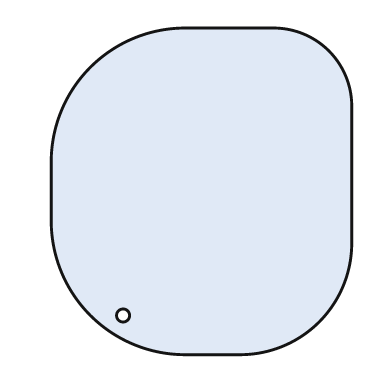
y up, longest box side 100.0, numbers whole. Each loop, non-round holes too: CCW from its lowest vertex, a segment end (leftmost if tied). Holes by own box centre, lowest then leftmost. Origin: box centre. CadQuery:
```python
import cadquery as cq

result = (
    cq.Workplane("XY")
    .moveTo(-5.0, -50.0)
    .lineTo(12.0, -50.0)
    .threePointArc((36.0, -40.0), (46.0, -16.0))
    .lineTo(46.0, 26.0)
    .threePointArc((39.0, 43.0), (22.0, 50.0))
    .lineTo(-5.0, 50.0)
    .threePointArc((-34.0, 38.0), (-46.0, 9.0))
    .lineTo(-46.0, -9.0)
    .threePointArc((-34.0, -38.0), (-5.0, -50.0))
    .close()
    .moveTo(-24.0, -38.0)
    .circle(2.0)
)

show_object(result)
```